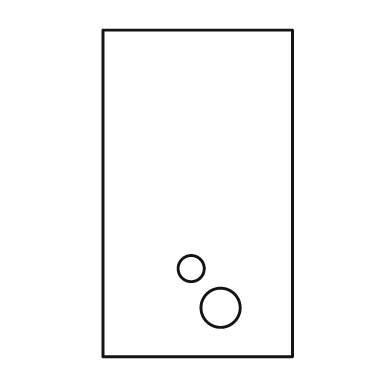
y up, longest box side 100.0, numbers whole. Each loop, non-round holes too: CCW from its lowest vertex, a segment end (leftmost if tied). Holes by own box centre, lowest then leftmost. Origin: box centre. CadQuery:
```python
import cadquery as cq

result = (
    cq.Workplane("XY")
    .moveTo(-29.0, -50.0)
    .lineTo(29.0, -50.0)
    .lineTo(29.0, 50.0)
    .lineTo(-29.0, 50.0)
    .close()
    .moveTo(7.0, -35.0)
    .circle(6.0)
    .moveTo(-2.0, -23.0)
    .circle(4.0)
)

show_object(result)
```